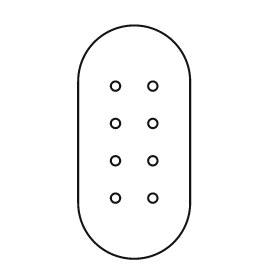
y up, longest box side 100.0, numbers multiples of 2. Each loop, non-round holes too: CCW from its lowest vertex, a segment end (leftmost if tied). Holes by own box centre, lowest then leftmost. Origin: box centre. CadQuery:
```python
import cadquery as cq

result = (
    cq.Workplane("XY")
    .moveTo(-24.0, -26.0)
    .threePointArc((0.0, -50.0), (24.0, -26.0))
    .lineTo(24.0, 26.0)
    .threePointArc((0.0, 50.0), (-24.0, 26.0))
    .close()
    .moveTo(-8.0, -24.0)
    .circle(2.0)
    .moveTo(8.0, -24.0)
    .circle(2.0)
    .moveTo(-8.0, -8.0)
    .circle(2.0)
    .moveTo(8.0, -8.0)
    .circle(2.0)
    .moveTo(-8.0, 8.0)
    .circle(2.0)
    .moveTo(8.0, 8.0)
    .circle(2.0)
    .moveTo(-8.0, 24.0)
    .circle(2.0)
    .moveTo(8.0, 24.0)
    .circle(2.0)
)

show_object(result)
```